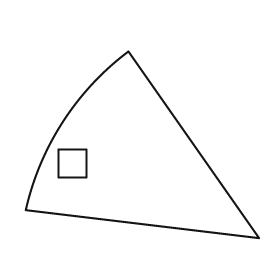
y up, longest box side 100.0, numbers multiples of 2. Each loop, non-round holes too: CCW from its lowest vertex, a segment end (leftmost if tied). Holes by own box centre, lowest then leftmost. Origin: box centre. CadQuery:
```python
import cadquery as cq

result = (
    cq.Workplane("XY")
    .moveTo(50.0, -40.0)
    .lineTo(-6.0, 40.0)
    .threePointArc((-34.0, 10.0), (-50.0, -28.0))
    .close()
    .moveTo(-36.0, -14.0)
    .lineTo(-24.0, -14.0)
    .lineTo(-24.0, -2.0)
    .lineTo(-36.0, -2.0)
    .close()
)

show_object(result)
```